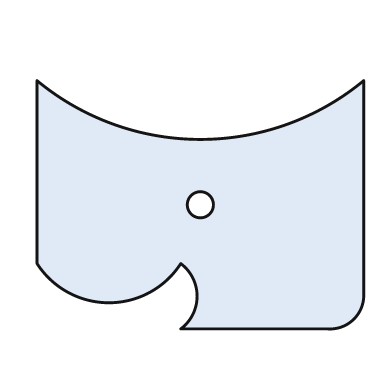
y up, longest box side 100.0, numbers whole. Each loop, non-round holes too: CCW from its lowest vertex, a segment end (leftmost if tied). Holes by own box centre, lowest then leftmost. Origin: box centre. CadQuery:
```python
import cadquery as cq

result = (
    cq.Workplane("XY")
    .moveTo(-6.0, -38.0)
    .lineTo(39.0, -38.0)
    .threePointArc((47.0, -35.0), (50.0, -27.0))
    .lineTo(50.0, 38.0)
    .threePointArc((0.0, 20.0), (-50.0, 38.0))
    .lineTo(-50.0, -18.0)
    .threePointArc((-28.0, -30.0), (-6.0, -18.0))
    .threePointArc((-1.0, -28.0), (-6.0, -38.0))
    .close()
    .moveTo(0.0, 0.0)
    .circle(4.0)
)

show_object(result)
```